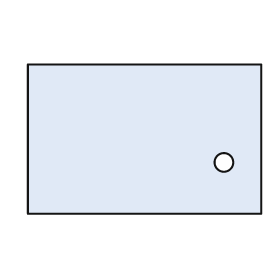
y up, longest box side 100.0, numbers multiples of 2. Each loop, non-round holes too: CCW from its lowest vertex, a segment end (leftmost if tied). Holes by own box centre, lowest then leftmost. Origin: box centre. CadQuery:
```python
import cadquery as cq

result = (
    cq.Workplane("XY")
    .moveTo(-50.0, -32.0)
    .lineTo(50.0, -32.0)
    .lineTo(50.0, 32.0)
    .lineTo(-50.0, 32.0)
    .close()
    .moveTo(34.0, -10.0)
    .circle(4.0)
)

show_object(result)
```